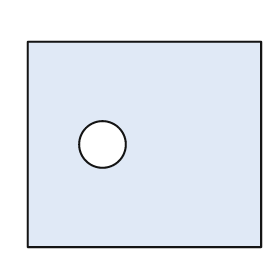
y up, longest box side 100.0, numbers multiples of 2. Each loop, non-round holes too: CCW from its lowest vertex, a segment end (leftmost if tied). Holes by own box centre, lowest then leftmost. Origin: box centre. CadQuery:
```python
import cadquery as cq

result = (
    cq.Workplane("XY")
    .moveTo(-50.0, -44.0)
    .lineTo(50.0, -44.0)
    .lineTo(50.0, 44.0)
    .lineTo(-50.0, 44.0)
    .close()
    .moveTo(-18.0, 0.0)
    .circle(10.0)
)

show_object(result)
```